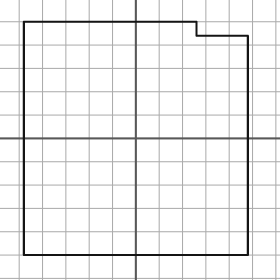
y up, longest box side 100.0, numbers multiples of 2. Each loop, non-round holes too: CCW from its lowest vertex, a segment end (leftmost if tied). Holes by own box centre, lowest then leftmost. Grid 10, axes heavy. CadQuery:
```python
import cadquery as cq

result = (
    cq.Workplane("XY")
    .moveTo(-48.0, -50.0)
    .lineTo(48.0, -50.0)
    .lineTo(48.0, 44.0)
    .lineTo(26.0, 44.0)
    .lineTo(26.0, 50.0)
    .lineTo(-48.0, 50.0)
    .close()
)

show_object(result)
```